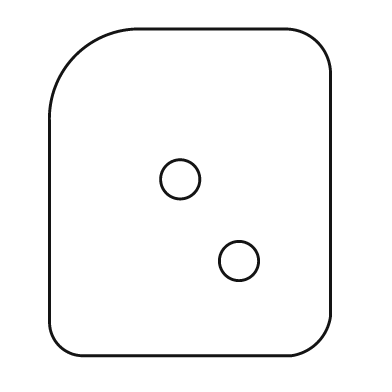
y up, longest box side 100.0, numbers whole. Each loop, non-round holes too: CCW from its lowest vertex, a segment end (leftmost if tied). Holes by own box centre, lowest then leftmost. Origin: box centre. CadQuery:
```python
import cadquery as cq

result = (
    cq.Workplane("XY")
    .moveTo(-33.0, -50.0)
    .lineTo(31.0, -50.0)
    .threePointArc((39.0, -46.0), (43.0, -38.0))
    .lineTo(43.0, 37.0)
    .threePointArc((39.0, 46.0), (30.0, 50.0))
    .lineTo(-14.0, 50.0)
    .threePointArc((-35.0, 42.0), (-43.0, 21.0))
    .lineTo(-43.0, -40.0)
    .threePointArc((-40.0, -47.0), (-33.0, -50.0))
    .close()
    .moveTo(15.0, -21.0)
    .circle(6.0)
    .moveTo(-3.0, 4.0)
    .circle(6.0)
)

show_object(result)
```